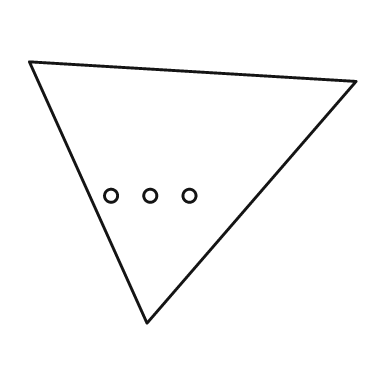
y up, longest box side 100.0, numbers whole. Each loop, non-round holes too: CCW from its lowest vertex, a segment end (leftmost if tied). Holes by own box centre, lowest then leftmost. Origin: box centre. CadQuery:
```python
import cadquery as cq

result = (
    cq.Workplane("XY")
    .moveTo(-14.0, -40.0)
    .lineTo(50.0, 34.0)
    .lineTo(-50.0, 40.0)
    .close()
    .moveTo(-25.0, -1.0)
    .circle(2.0)
    .moveTo(-13.0, -1.0)
    .circle(2.0)
    .moveTo(-1.0, -1.0)
    .circle(2.0)
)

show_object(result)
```